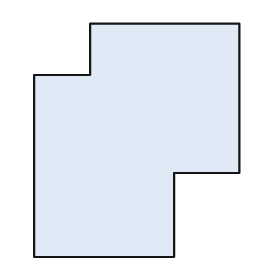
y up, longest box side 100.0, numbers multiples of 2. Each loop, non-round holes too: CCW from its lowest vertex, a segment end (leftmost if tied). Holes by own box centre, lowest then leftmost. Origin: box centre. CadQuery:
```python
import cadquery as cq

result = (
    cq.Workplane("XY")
    .moveTo(-44.0, -50.0)
    .lineTo(16.0, -50.0)
    .lineTo(16.0, -14.0)
    .lineTo(44.0, -14.0)
    .lineTo(44.0, 50.0)
    .lineTo(-20.0, 50.0)
    .lineTo(-20.0, 28.0)
    .lineTo(-44.0, 28.0)
    .close()
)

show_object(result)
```